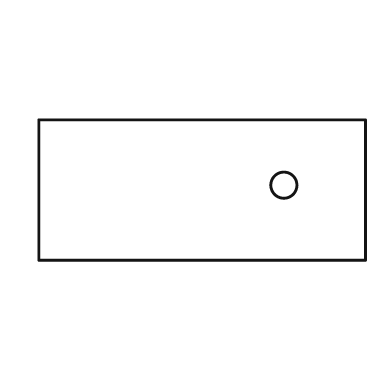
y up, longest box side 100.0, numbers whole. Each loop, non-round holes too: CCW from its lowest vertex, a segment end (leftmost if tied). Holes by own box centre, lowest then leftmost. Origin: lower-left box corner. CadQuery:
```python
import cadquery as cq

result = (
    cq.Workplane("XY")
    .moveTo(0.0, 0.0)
    .lineTo(100.0, 0.0)
    .lineTo(100.0, 43.0)
    .lineTo(0.0, 43.0)
    .close()
    .moveTo(75.0, 23.0)
    .circle(4.0)
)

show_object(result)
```